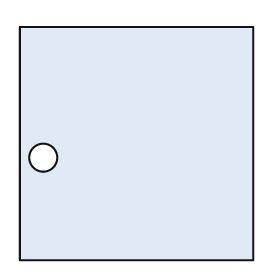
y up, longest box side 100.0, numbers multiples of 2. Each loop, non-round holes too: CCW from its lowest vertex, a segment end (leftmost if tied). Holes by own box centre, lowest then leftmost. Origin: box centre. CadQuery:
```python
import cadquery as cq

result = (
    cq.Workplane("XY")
    .moveTo(-50.0, -50.0)
    .lineTo(50.0, -50.0)
    .lineTo(50.0, 50.0)
    .lineTo(-50.0, 50.0)
    .close()
    .moveTo(-40.0, -6.0)
    .circle(6.0)
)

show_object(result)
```